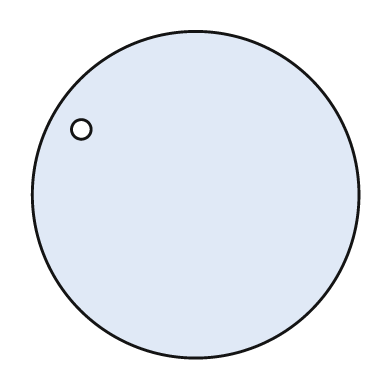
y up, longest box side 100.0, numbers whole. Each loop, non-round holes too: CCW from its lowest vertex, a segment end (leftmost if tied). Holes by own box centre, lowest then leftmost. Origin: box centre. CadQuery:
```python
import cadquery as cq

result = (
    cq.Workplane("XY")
    .moveTo(0.0, 0.0)
    .circle(50.0)
    .moveTo(-35.0, 20.0)
    .circle(3.0)
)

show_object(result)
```